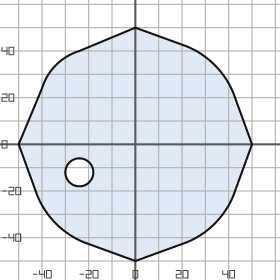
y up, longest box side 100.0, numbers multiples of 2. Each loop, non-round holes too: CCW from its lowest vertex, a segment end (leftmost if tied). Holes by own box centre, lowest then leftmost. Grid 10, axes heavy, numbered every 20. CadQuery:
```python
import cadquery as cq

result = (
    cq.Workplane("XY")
    .moveTo(0.0, -50.0)
    .lineTo(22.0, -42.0)
    .threePointArc((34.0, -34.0), (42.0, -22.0))
    .lineTo(50.0, 0.0)
    .lineTo(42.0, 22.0)
    .threePointArc((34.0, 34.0), (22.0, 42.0))
    .lineTo(0.0, 50.0)
    .lineTo(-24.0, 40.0)
    .threePointArc((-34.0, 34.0), (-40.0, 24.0))
    .lineTo(-50.0, 0.0)
    .lineTo(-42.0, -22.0)
    .threePointArc((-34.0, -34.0), (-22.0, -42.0))
    .close()
    .moveTo(-24.0, -12.0)
    .circle(6.0)
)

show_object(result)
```